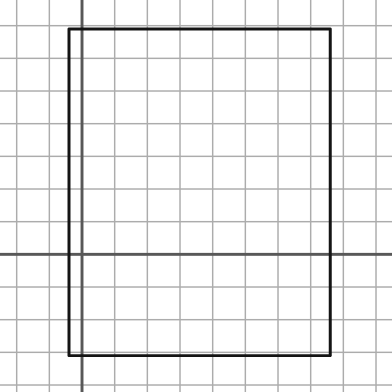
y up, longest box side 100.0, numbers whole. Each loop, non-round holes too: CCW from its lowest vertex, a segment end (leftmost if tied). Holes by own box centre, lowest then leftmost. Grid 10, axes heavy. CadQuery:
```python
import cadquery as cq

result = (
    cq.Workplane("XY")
    .moveTo(-4.0, -31.0)
    .lineTo(76.0, -31.0)
    .lineTo(76.0, 69.0)
    .lineTo(-4.0, 69.0)
    .close()
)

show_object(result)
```